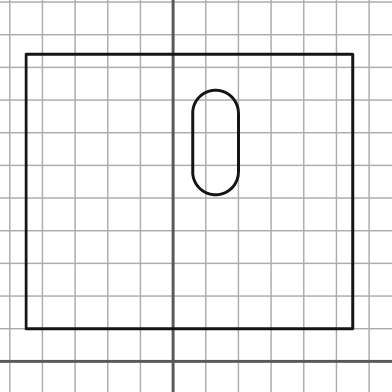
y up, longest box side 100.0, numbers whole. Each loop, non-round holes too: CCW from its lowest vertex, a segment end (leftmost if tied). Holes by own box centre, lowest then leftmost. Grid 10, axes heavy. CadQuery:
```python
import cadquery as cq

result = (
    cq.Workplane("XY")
    .moveTo(-45.0, 10.0)
    .lineTo(55.0, 10.0)
    .lineTo(55.0, 94.0)
    .lineTo(-45.0, 94.0)
    .close()
    .moveTo(6.0, 58.0)
    .threePointArc((13.0, 51.0), (20.0, 58.0))
    .lineTo(20.0, 76.0)
    .threePointArc((13.0, 83.0), (6.0, 76.0))
    .close()
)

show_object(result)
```